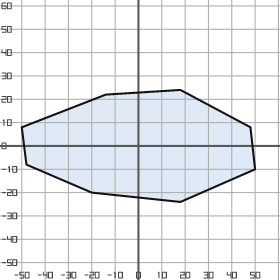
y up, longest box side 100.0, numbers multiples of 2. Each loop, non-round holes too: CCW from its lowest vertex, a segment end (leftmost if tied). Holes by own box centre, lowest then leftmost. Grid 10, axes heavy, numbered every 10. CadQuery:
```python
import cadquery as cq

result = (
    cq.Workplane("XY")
    .moveTo(18.0, -24.0)
    .lineTo(50.0, -10.0)
    .lineTo(48.0, 8.0)
    .lineTo(18.0, 24.0)
    .lineTo(-14.0, 22.0)
    .lineTo(-50.0, 8.0)
    .lineTo(-48.0, -8.0)
    .lineTo(-20.0, -20.0)
    .close()
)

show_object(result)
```